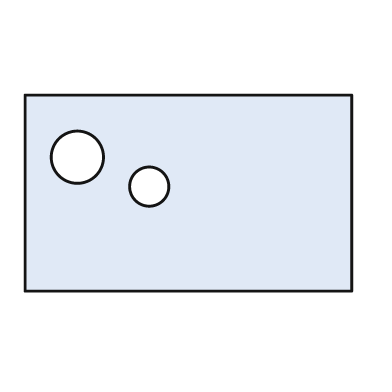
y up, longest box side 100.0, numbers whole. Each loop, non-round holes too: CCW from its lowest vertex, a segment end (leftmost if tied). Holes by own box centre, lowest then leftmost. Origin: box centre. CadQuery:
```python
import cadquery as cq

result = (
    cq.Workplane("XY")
    .moveTo(-50.0, -30.0)
    .lineTo(50.0, -30.0)
    .lineTo(50.0, 30.0)
    .lineTo(-50.0, 30.0)
    .close()
    .moveTo(-12.0, 2.0)
    .circle(6.0)
    .moveTo(-34.0, 11.0)
    .circle(8.0)
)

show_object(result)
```